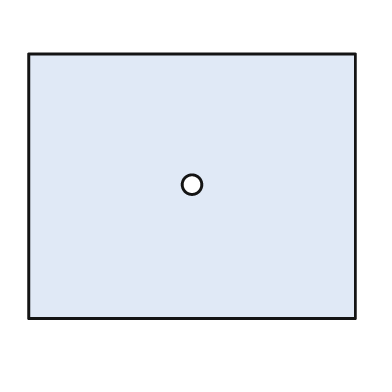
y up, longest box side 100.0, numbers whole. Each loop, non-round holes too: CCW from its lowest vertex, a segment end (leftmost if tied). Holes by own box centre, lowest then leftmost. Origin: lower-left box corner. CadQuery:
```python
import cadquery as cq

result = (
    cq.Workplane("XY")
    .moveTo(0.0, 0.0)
    .lineTo(100.0, 0.0)
    .lineTo(100.0, 81.0)
    .lineTo(0.0, 81.0)
    .close()
    .moveTo(50.0, 41.0)
    .circle(3.0)
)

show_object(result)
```